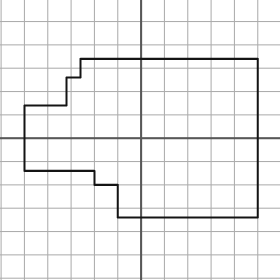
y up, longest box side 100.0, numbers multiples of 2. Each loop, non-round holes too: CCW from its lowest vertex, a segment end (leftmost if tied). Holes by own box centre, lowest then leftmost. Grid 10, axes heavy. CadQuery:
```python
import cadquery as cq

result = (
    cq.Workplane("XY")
    .moveTo(-10.0, -34.0)
    .lineTo(50.0, -34.0)
    .lineTo(50.0, 34.0)
    .lineTo(-26.0, 34.0)
    .lineTo(-26.0, 26.0)
    .lineTo(-32.0, 26.0)
    .lineTo(-32.0, 14.0)
    .lineTo(-50.0, 14.0)
    .lineTo(-50.0, -14.0)
    .lineTo(-20.0, -14.0)
    .lineTo(-20.0, -20.0)
    .lineTo(-10.0, -20.0)
    .close()
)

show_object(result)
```